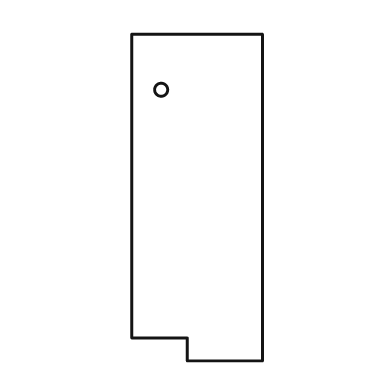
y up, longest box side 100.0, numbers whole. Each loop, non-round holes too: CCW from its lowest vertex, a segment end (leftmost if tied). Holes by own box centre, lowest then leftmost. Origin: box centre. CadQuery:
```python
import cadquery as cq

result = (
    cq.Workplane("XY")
    .moveTo(-3.0, -50.0)
    .lineTo(20.0, -50.0)
    .lineTo(20.0, 50.0)
    .lineTo(-20.0, 50.0)
    .lineTo(-20.0, -43.0)
    .lineTo(-3.0, -43.0)
    .close()
    .moveTo(-11.0, 33.0)
    .circle(2.0)
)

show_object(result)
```